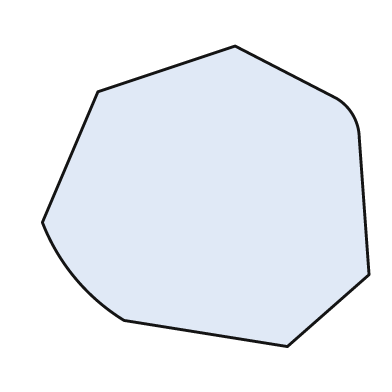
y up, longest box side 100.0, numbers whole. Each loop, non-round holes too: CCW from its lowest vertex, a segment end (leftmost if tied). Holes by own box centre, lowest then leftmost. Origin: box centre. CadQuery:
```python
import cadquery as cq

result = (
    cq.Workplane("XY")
    .moveTo(25.0, -46.0)
    .lineTo(50.0, -24.0)
    .lineTo(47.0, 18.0)
    .threePointArc((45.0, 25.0), (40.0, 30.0))
    .lineTo(9.0, 46.0)
    .lineTo(-33.0, 32.0)
    .lineTo(-50.0, -8.0)
    .threePointArc((-40.0, -25.0), (-25.0, -38.0))
    .close()
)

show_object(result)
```